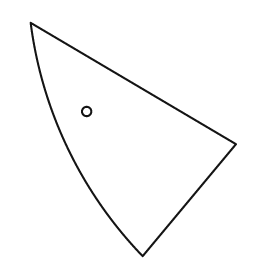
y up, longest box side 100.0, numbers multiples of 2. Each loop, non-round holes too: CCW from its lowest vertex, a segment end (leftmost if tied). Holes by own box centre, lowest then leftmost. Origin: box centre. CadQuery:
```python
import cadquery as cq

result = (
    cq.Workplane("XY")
    .moveTo(4.0, -50.0)
    .lineTo(44.0, -2.0)
    .lineTo(-44.0, 50.0)
    .threePointArc((-28.0, -4.0), (4.0, -50.0))
    .close()
    .moveTo(-20.0, 12.0)
    .circle(2.0)
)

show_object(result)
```